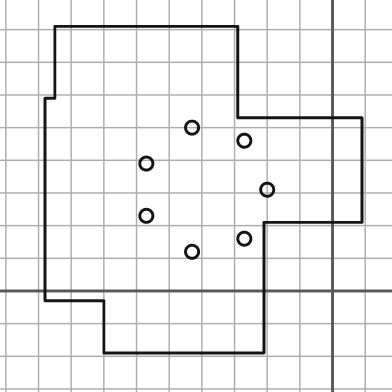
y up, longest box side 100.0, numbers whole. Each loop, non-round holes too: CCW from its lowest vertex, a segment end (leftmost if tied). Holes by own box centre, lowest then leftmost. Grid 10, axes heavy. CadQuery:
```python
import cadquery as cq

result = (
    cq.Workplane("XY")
    .moveTo(-70.0, -19.0)
    .lineTo(-21.0, -19.0)
    .lineTo(-21.0, 21.0)
    .lineTo(9.0, 21.0)
    .lineTo(9.0, 53.0)
    .lineTo(-29.0, 53.0)
    .lineTo(-29.0, 81.0)
    .lineTo(-85.0, 81.0)
    .lineTo(-85.0, 59.0)
    .lineTo(-88.0, 59.0)
    .lineTo(-88.0, -3.0)
    .lineTo(-70.0, -3.0)
    .close()
    .moveTo(-43.0, 12.0)
    .circle(2.0)
    .moveTo(-27.0, 16.0)
    .circle(2.0)
    .moveTo(-57.0, 23.0)
    .circle(2.0)
    .moveTo(-20.0, 31.0)
    .circle(2.0)
    .moveTo(-57.0, 39.0)
    .circle(2.0)
    .moveTo(-27.0, 46.0)
    .circle(2.0)
    .moveTo(-43.0, 50.0)
    .circle(2.0)
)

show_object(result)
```